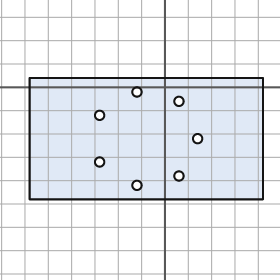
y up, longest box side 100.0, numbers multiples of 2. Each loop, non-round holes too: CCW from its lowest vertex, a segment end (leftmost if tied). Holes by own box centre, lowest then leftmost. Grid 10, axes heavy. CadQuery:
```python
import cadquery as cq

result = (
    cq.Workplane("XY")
    .moveTo(-58.0, -48.0)
    .lineTo(42.0, -48.0)
    .lineTo(42.0, 4.0)
    .lineTo(-58.0, 4.0)
    .close()
    .moveTo(-12.0, -42.0)
    .circle(2.0)
    .moveTo(6.0, -38.0)
    .circle(2.0)
    .moveTo(-28.0, -32.0)
    .circle(2.0)
    .moveTo(14.0, -22.0)
    .circle(2.0)
    .moveTo(-28.0, -12.0)
    .circle(2.0)
    .moveTo(6.0, -6.0)
    .circle(2.0)
    .moveTo(-12.0, -2.0)
    .circle(2.0)
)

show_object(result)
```